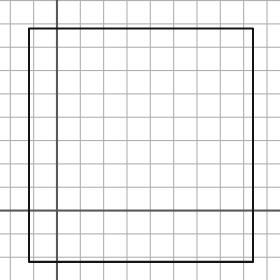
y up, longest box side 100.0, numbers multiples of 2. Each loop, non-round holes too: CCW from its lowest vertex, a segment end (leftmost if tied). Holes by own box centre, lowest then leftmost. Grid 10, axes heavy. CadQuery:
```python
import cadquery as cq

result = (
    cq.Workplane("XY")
    .moveTo(-12.0, -22.0)
    .lineTo(84.0, -22.0)
    .lineTo(84.0, 78.0)
    .lineTo(-12.0, 78.0)
    .close()
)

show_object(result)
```